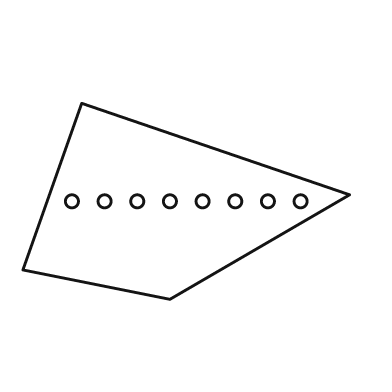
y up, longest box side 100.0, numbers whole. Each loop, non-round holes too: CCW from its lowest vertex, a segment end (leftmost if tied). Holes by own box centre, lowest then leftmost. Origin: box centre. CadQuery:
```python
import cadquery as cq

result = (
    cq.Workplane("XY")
    .moveTo(-5.0, -30.0)
    .lineTo(50.0, 2.0)
    .lineTo(-32.0, 30.0)
    .lineTo(-50.0, -21.0)
    .close()
    .moveTo(-35.0, 0.0)
    .circle(2.0)
    .moveTo(-25.0, 0.0)
    .circle(2.0)
    .moveTo(-15.0, 0.0)
    .circle(2.0)
    .moveTo(-5.0, 0.0)
    .circle(2.0)
    .moveTo(5.0, 0.0)
    .circle(2.0)
    .moveTo(15.0, 0.0)
    .circle(2.0)
    .moveTo(25.0, 0.0)
    .circle(2.0)
    .moveTo(35.0, 0.0)
    .circle(2.0)
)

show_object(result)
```